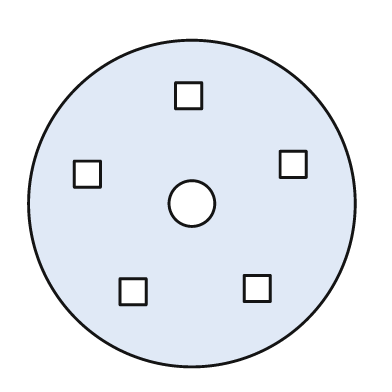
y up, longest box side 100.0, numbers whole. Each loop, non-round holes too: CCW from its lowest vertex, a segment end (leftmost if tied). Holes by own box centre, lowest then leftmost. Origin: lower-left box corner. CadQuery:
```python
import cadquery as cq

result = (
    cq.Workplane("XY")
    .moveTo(50.0, 50.0)
    .circle(50.0)
    .moveTo(28.0, 19.0)
    .lineTo(36.0, 19.0)
    .lineTo(36.0, 27.0)
    .lineTo(28.0, 27.0)
    .close()
    .moveTo(66.0, 20.0)
    .lineTo(74.0, 20.0)
    .lineTo(74.0, 28.0)
    .lineTo(66.0, 28.0)
    .close()
    .moveTo(50.0, 50.0)
    .circle(7.0)
    .moveTo(14.0, 55.0)
    .lineTo(22.0, 55.0)
    .lineTo(22.0, 63.0)
    .lineTo(14.0, 63.0)
    .close()
    .moveTo(77.0, 58.0)
    .lineTo(85.0, 58.0)
    .lineTo(85.0, 66.0)
    .lineTo(77.0, 66.0)
    .close()
    .moveTo(45.0, 79.0)
    .lineTo(53.0, 79.0)
    .lineTo(53.0, 87.0)
    .lineTo(45.0, 87.0)
    .close()
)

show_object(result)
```